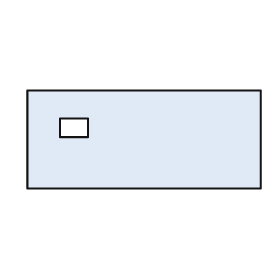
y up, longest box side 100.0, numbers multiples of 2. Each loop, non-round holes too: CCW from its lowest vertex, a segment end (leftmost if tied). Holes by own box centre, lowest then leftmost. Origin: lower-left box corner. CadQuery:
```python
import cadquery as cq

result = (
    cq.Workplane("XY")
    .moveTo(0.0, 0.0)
    .lineTo(100.0, 0.0)
    .lineTo(100.0, 42.0)
    .lineTo(0.0, 42.0)
    .close()
    .moveTo(14.0, 22.0)
    .lineTo(26.0, 22.0)
    .lineTo(26.0, 30.0)
    .lineTo(14.0, 30.0)
    .close()
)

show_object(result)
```